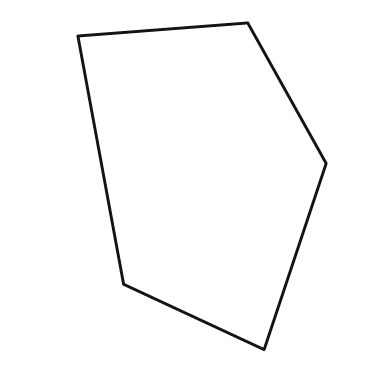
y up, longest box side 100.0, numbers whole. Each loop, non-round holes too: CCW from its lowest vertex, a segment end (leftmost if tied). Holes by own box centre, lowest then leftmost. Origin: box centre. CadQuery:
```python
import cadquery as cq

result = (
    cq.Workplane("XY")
    .moveTo(19.0, -50.0)
    .lineTo(38.0, 7.0)
    .lineTo(14.0, 50.0)
    .lineTo(-38.0, 46.0)
    .lineTo(-24.0, -30.0)
    .close()
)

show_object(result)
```